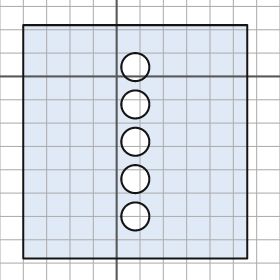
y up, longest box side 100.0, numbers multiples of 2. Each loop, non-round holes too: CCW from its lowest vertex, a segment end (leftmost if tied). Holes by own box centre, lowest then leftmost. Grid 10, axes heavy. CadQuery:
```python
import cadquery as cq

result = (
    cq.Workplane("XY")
    .moveTo(-40.0, -78.0)
    .lineTo(56.0, -78.0)
    .lineTo(56.0, 22.0)
    .lineTo(-40.0, 22.0)
    .close()
    .moveTo(8.0, -60.0)
    .circle(6.0)
    .moveTo(8.0, -44.0)
    .circle(6.0)
    .moveTo(8.0, -28.0)
    .circle(6.0)
    .moveTo(8.0, -12.0)
    .circle(6.0)
    .moveTo(8.0, 4.0)
    .circle(6.0)
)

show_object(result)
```